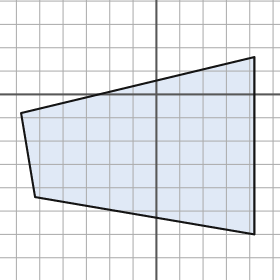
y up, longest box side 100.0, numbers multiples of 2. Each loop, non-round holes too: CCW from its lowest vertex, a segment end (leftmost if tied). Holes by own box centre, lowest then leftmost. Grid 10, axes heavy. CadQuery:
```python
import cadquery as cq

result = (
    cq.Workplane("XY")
    .moveTo(42.0, -60.0)
    .lineTo(42.0, 16.0)
    .lineTo(-58.0, -8.0)
    .lineTo(-52.0, -44.0)
    .close()
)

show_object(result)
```